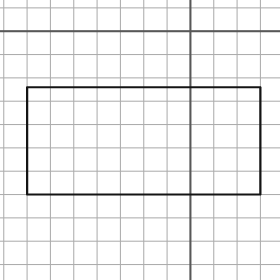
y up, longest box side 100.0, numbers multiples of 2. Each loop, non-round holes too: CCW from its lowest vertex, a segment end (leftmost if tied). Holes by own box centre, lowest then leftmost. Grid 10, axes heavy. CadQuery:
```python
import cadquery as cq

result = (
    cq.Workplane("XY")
    .moveTo(-70.0, -70.0)
    .lineTo(30.0, -70.0)
    .lineTo(30.0, -24.0)
    .lineTo(-70.0, -24.0)
    .close()
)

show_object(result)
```